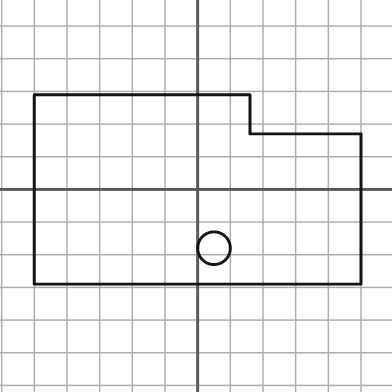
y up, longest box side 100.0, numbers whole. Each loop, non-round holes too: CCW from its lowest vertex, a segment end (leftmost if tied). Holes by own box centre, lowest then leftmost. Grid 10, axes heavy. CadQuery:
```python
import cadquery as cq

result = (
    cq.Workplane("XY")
    .moveTo(-50.0, -29.0)
    .lineTo(50.0, -29.0)
    .lineTo(50.0, 17.0)
    .lineTo(16.0, 17.0)
    .lineTo(16.0, 29.0)
    .lineTo(-50.0, 29.0)
    .close()
    .moveTo(5.0, -18.0)
    .circle(5.0)
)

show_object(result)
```